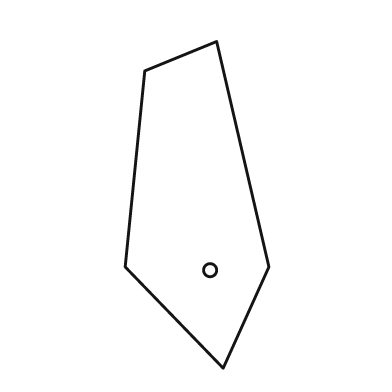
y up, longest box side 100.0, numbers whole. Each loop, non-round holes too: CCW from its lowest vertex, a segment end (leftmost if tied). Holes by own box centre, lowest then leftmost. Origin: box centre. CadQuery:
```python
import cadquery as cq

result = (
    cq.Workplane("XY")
    .moveTo(8.0, -50.0)
    .lineTo(22.0, -19.0)
    .lineTo(6.0, 50.0)
    .lineTo(-16.0, 41.0)
    .lineTo(-22.0, -19.0)
    .close()
    .moveTo(4.0, -20.0)
    .circle(2.0)
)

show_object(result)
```